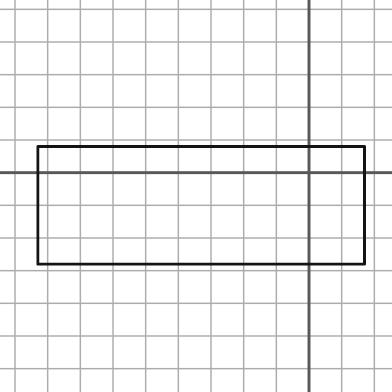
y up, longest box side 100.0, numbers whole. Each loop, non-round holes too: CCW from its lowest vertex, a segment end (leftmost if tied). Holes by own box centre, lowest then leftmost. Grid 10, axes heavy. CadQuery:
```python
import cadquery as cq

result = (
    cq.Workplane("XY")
    .moveTo(-83.0, -28.0)
    .lineTo(17.0, -28.0)
    .lineTo(17.0, 8.0)
    .lineTo(-83.0, 8.0)
    .close()
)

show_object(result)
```